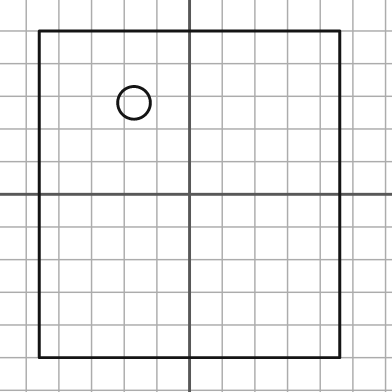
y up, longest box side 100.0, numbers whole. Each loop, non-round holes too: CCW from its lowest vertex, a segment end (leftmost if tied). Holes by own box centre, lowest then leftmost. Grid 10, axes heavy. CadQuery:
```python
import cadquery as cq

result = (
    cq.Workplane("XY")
    .moveTo(-46.0, -50.0)
    .lineTo(46.0, -50.0)
    .lineTo(46.0, 50.0)
    .lineTo(-46.0, 50.0)
    .close()
    .moveTo(-17.0, 28.0)
    .circle(5.0)
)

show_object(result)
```